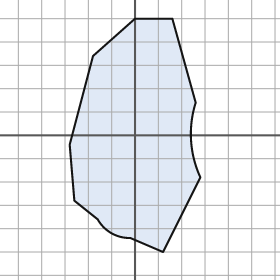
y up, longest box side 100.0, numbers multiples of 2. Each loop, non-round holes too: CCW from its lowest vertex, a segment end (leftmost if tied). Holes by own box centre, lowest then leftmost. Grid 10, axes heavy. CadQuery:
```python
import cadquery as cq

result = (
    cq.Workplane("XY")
    .moveTo(12.0, -50.0)
    .lineTo(28.0, -18.0)
    .threePointArc((24.0, -2.0), (26.0, 14.0))
    .lineTo(16.0, 50.0)
    .lineTo(0.0, 50.0)
    .lineTo(-18.0, 34.0)
    .lineTo(-28.0, -4.0)
    .lineTo(-26.0, -28.0)
    .lineTo(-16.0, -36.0)
    .threePointArc((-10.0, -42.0), (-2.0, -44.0))
    .close()
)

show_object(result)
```